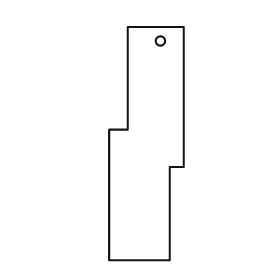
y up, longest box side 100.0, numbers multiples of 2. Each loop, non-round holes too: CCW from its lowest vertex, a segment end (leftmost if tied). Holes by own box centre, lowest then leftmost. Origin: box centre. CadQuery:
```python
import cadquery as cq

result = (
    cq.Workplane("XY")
    .moveTo(-16.0, -50.0)
    .lineTo(10.0, -50.0)
    .lineTo(10.0, -10.0)
    .lineTo(16.0, -10.0)
    .lineTo(16.0, 50.0)
    .lineTo(-8.0, 50.0)
    .lineTo(-8.0, 6.0)
    .lineTo(-16.0, 6.0)
    .close()
    .moveTo(6.0, 44.0)
    .circle(2.0)
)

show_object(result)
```